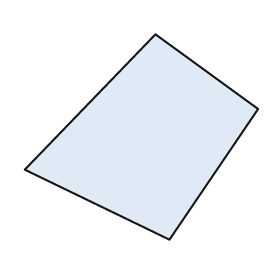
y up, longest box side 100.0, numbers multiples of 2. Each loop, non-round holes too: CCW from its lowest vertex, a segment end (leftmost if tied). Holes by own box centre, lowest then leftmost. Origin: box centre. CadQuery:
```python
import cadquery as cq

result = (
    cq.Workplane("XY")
    .moveTo(12.0, -44.0)
    .lineTo(50.0, 12.0)
    .lineTo(6.0, 44.0)
    .lineTo(-50.0, -14.0)
    .close()
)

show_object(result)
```